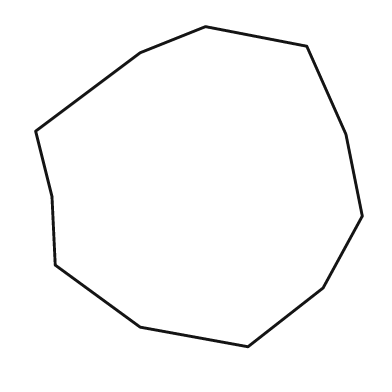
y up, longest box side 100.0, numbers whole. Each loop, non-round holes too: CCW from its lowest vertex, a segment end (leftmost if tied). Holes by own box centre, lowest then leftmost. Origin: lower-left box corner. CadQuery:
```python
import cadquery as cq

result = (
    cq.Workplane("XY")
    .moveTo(65.0, 0.0)
    .lineTo(88.0, 18.0)
    .lineTo(100.0, 40.0)
    .lineTo(95.0, 65.0)
    .lineTo(83.0, 92.0)
    .lineTo(52.0, 98.0)
    .lineTo(32.0, 90.0)
    .lineTo(0.0, 66.0)
    .lineTo(5.0, 46.0)
    .lineTo(6.0, 25.0)
    .lineTo(32.0, 6.0)
    .close()
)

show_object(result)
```